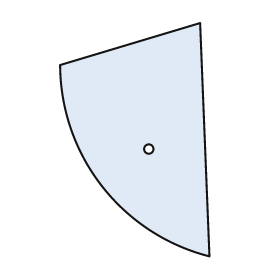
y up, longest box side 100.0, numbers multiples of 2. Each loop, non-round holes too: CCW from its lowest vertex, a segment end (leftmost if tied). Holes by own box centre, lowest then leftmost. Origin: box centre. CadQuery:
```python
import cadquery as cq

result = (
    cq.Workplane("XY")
    .moveTo(32.0, -50.0)
    .lineTo(28.0, 50.0)
    .lineTo(-32.0, 32.0)
    .threePointArc((-14.0, -20.0), (32.0, -50.0))
    .close()
    .moveTo(6.0, -4.0)
    .circle(2.0)
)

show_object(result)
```